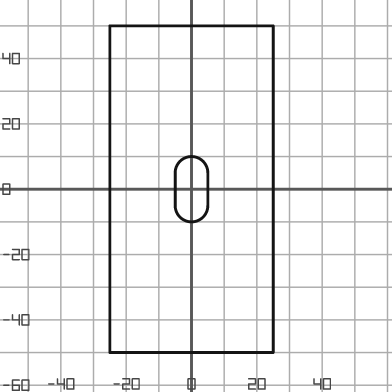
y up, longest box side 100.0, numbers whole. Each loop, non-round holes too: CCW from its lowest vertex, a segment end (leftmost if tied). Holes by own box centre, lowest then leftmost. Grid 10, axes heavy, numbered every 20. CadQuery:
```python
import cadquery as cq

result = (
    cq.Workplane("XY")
    .moveTo(-25.0, -50.0)
    .lineTo(25.0, -50.0)
    .lineTo(25.0, 50.0)
    .lineTo(-25.0, 50.0)
    .close()
    .moveTo(-5.0, -5.0)
    .threePointArc((0.0, -10.0), (5.0, -5.0))
    .lineTo(5.0, 5.0)
    .threePointArc((0.0, 10.0), (-5.0, 5.0))
    .close()
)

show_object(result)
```